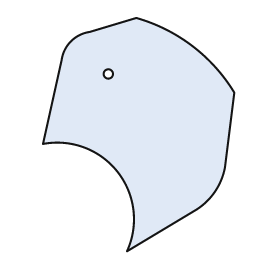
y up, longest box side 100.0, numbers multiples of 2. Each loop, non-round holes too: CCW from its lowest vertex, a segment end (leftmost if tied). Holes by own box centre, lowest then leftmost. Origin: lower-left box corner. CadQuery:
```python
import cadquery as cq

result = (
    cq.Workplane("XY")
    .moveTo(36.0, 0.0)
    .lineTo(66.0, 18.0)
    .threePointArc((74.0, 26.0), (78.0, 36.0))
    .lineTo(82.0, 68.0)
    .threePointArc((64.0, 88.0), (40.0, 100.0))
    .lineTo(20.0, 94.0)
    .threePointArc((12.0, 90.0), (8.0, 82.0))
    .lineTo(0.0, 46.0)
    .threePointArc((32.0, 34.0), (36.0, 0.0))
    .close()
    .moveTo(28.0, 76.0)
    .circle(2.0)
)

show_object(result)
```